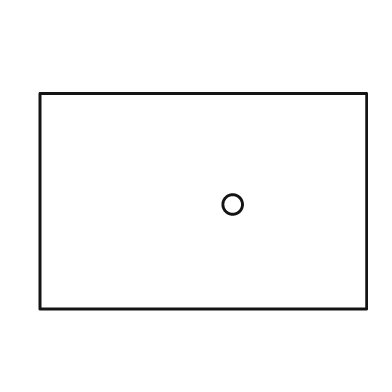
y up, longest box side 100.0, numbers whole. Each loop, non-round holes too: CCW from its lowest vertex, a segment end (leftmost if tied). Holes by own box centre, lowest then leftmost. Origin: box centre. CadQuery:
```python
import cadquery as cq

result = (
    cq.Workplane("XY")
    .moveTo(-50.0, -33.0)
    .lineTo(50.0, -33.0)
    .lineTo(50.0, 33.0)
    .lineTo(-50.0, 33.0)
    .close()
    .moveTo(9.0, -1.0)
    .circle(3.0)
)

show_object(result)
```